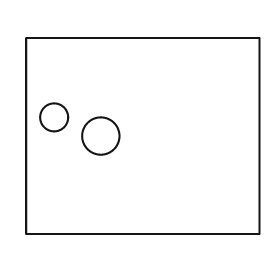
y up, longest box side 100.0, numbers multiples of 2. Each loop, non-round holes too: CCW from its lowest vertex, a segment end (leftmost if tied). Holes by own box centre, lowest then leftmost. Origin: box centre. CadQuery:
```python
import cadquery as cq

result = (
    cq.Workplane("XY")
    .moveTo(-50.0, -42.0)
    .lineTo(50.0, -42.0)
    .lineTo(50.0, 42.0)
    .lineTo(-50.0, 42.0)
    .close()
    .moveTo(-18.0, 0.0)
    .circle(8.0)
    .moveTo(-38.0, 8.0)
    .circle(6.0)
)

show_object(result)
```